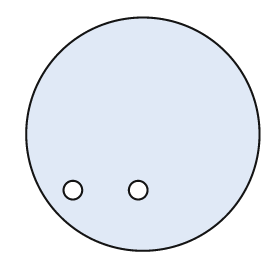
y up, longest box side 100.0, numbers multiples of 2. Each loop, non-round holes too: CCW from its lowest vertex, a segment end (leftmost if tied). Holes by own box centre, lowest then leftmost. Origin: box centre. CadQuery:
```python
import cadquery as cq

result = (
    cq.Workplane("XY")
    .moveTo(0.0, 0.0)
    .circle(50.0)
    .moveTo(-30.0, -24.0)
    .circle(4.0)
    .moveTo(-2.0, -24.0)
    .circle(4.0)
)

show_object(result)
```